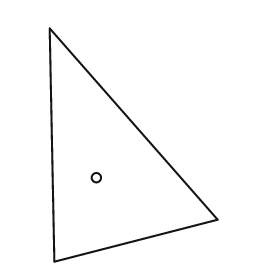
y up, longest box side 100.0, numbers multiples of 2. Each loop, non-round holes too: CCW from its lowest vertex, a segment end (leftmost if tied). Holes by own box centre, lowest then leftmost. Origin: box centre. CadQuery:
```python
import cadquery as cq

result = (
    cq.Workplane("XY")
    .moveTo(-34.0, -50.0)
    .lineTo(36.0, -32.0)
    .lineTo(-36.0, 50.0)
    .close()
    .moveTo(-16.0, -14.0)
    .circle(2.0)
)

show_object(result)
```